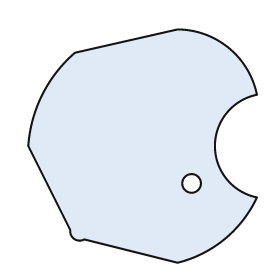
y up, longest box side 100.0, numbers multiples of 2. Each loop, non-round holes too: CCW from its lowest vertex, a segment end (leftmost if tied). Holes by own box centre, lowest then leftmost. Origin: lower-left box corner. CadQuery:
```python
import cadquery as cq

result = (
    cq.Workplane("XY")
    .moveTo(64.0, 0.0)
    .threePointArc((84.0, 10.0), (98.0, 28.0))
    .threePointArc((80.0, 50.0), (98.0, 72.0))
    .threePointArc((86.0, 92.0), (64.0, 100.0))
    .lineTo(20.0, 90.0)
    .threePointArc((6.0, 72.0), (0.0, 50.0))
    .lineTo(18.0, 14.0)
    .threePointArc((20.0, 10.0), (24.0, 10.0))
    .close()
    .moveTo(70.0, 34.0)
    .circle(4.0)
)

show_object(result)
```